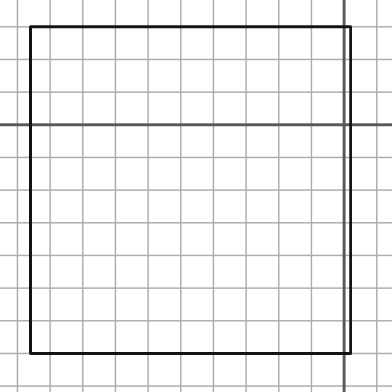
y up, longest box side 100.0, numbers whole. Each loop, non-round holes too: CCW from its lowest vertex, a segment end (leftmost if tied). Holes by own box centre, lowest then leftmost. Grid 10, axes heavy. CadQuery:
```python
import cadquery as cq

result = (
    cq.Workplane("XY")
    .moveTo(-96.0, -70.0)
    .lineTo(2.0, -70.0)
    .lineTo(2.0, 30.0)
    .lineTo(-96.0, 30.0)
    .close()
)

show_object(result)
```